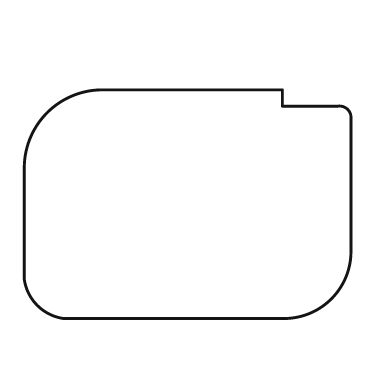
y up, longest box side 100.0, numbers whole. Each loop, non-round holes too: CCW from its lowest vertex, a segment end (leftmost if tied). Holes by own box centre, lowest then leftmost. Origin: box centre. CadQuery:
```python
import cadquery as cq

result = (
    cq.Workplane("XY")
    .moveTo(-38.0, -35.0)
    .lineTo(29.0, -35.0)
    .threePointArc((44.0, -29.0), (50.0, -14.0))
    .lineTo(50.0, 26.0)
    .threePointArc((49.0, 29.0), (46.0, 30.0))
    .lineTo(29.0, 30.0)
    .lineTo(29.0, 35.0)
    .lineTo(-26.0, 35.0)
    .threePointArc((-43.0, 28.0), (-50.0, 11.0))
    .lineTo(-50.0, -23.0)
    .threePointArc((-46.0, -31.0), (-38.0, -35.0))
    .close()
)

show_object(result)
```